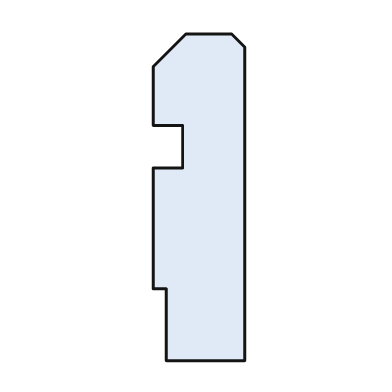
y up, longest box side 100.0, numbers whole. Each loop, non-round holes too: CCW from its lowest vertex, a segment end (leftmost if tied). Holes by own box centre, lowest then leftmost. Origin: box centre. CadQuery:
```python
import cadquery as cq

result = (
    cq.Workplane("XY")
    .moveTo(-10.0, -50.0)
    .lineTo(14.0, -50.0)
    .lineTo(14.0, 46.0)
    .lineTo(10.0, 50.0)
    .lineTo(-4.0, 50.0)
    .lineTo(-14.0, 40.0)
    .lineTo(-14.0, 22.0)
    .lineTo(-5.0, 22.0)
    .lineTo(-5.0, 9.0)
    .lineTo(-14.0, 9.0)
    .lineTo(-14.0, -28.0)
    .lineTo(-10.0, -28.0)
    .close()
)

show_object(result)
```